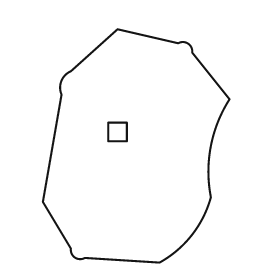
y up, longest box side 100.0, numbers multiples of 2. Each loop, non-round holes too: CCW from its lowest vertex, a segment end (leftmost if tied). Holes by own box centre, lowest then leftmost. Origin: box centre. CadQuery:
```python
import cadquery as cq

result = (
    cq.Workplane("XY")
    .moveTo(10.0, -50.0)
    .threePointArc((24.0, -38.0), (32.0, -22.0))
    .threePointArc((32.0, 0.0), (40.0, 20.0))
    .lineTo(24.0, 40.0)
    .threePointArc((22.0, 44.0), (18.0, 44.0))
    .lineTo(-8.0, 50.0)
    .lineTo(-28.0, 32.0)
    .threePointArc((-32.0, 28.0), (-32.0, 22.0))
    .lineTo(-40.0, -24.0)
    .lineTo(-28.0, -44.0)
    .threePointArc((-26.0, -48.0), (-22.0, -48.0))
    .close()
    .moveTo(-12.0, 2.0)
    .lineTo(-4.0, 2.0)
    .lineTo(-4.0, 10.0)
    .lineTo(-12.0, 10.0)
    .close()
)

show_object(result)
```